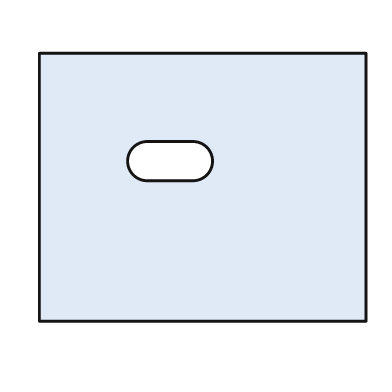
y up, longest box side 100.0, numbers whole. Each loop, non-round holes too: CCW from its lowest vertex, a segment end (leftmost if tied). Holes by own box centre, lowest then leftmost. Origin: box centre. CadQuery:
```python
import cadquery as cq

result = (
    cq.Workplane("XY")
    .moveTo(-50.0, -41.0)
    .lineTo(50.0, -41.0)
    .lineTo(50.0, 41.0)
    .lineTo(-50.0, 41.0)
    .close()
    .moveTo(-17.0, 2.0)
    .lineTo(-3.0, 2.0)
    .threePointArc((3.0, 8.0), (-3.0, 14.0))
    .lineTo(-17.0, 14.0)
    .threePointArc((-23.0, 8.0), (-17.0, 2.0))
    .close()
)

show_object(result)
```